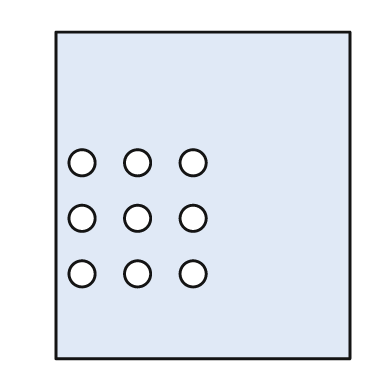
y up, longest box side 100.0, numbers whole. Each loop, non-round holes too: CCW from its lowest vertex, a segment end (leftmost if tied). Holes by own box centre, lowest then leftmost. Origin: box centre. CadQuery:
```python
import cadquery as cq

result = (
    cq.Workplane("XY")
    .moveTo(-45.0, -50.0)
    .lineTo(45.0, -50.0)
    .lineTo(45.0, 50.0)
    .lineTo(-45.0, 50.0)
    .close()
    .moveTo(-37.0, -24.0)
    .circle(4.0)
    .moveTo(-20.0, -24.0)
    .circle(4.0)
    .moveTo(-3.0, -24.0)
    .circle(4.0)
    .moveTo(-37.0, -7.0)
    .circle(4.0)
    .moveTo(-20.0, -7.0)
    .circle(4.0)
    .moveTo(-3.0, -7.0)
    .circle(4.0)
    .moveTo(-37.0, 10.0)
    .circle(4.0)
    .moveTo(-20.0, 10.0)
    .circle(4.0)
    .moveTo(-3.0, 10.0)
    .circle(4.0)
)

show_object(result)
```